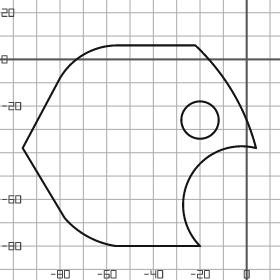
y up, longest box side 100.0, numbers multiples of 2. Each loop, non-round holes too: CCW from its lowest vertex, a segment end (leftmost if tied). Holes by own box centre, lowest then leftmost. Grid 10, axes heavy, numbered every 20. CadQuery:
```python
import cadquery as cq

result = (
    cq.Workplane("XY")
    .moveTo(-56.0, -80.0)
    .lineTo(-20.0, -80.0)
    .threePointArc((-24.0, -50.0), (4.0, -38.0))
    .threePointArc((-6.0, -14.0), (-22.0, 6.0))
    .lineTo(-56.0, 6.0)
    .threePointArc((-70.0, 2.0), (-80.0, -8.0))
    .lineTo(-96.0, -38.0)
    .lineTo(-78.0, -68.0)
    .threePointArc((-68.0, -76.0), (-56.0, -80.0))
    .close()
    .moveTo(-20.0, -26.0)
    .circle(8.0)
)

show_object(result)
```